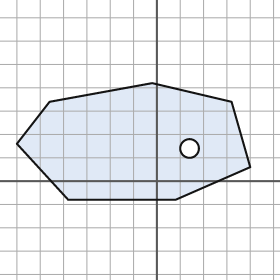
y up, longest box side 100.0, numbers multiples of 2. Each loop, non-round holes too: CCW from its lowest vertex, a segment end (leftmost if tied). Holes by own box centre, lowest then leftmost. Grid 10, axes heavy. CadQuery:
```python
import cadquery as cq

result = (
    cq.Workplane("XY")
    .moveTo(-38.0, -8.0)
    .lineTo(8.0, -8.0)
    .lineTo(40.0, 6.0)
    .lineTo(32.0, 34.0)
    .lineTo(-2.0, 42.0)
    .lineTo(-46.0, 34.0)
    .lineTo(-60.0, 16.0)
    .close()
    .moveTo(14.0, 14.0)
    .circle(4.0)
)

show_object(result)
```